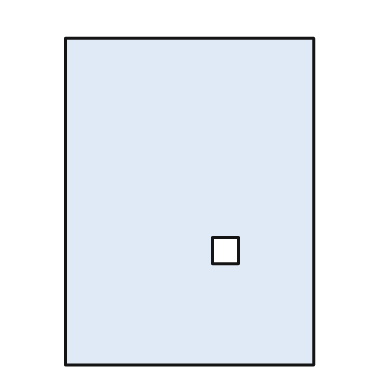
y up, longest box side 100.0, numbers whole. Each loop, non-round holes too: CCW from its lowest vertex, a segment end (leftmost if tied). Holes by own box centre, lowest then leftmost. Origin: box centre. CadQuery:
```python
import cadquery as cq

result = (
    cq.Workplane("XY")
    .moveTo(-38.0, -50.0)
    .lineTo(38.0, -50.0)
    .lineTo(38.0, 50.0)
    .lineTo(-38.0, 50.0)
    .close()
    .moveTo(7.0, -19.0)
    .lineTo(15.0, -19.0)
    .lineTo(15.0, -11.0)
    .lineTo(7.0, -11.0)
    .close()
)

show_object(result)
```